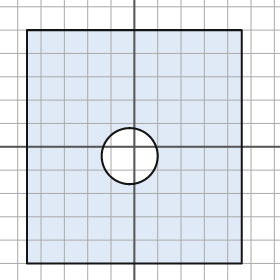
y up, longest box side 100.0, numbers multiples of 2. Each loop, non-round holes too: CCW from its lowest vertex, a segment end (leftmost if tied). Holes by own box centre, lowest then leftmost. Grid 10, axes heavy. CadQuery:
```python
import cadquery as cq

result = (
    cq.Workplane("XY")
    .moveTo(-46.0, -50.0)
    .lineTo(46.0, -50.0)
    .lineTo(46.0, 50.0)
    .lineTo(-46.0, 50.0)
    .close()
    .moveTo(-2.0, -4.0)
    .circle(12.0)
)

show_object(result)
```